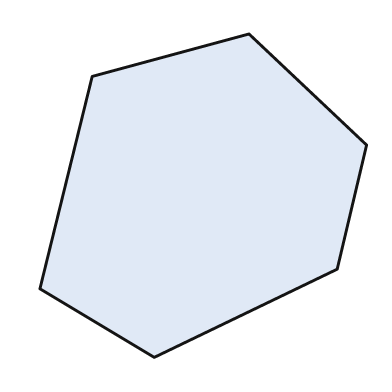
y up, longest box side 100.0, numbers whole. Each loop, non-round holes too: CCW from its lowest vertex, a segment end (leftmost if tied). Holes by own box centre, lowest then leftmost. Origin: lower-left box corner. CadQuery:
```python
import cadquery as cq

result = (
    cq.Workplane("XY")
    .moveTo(35.0, 0.0)
    .lineTo(91.0, 27.0)
    .lineTo(100.0, 65.0)
    .lineTo(64.0, 99.0)
    .lineTo(16.0, 86.0)
    .lineTo(0.0, 21.0)
    .close()
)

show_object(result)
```